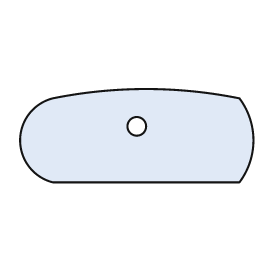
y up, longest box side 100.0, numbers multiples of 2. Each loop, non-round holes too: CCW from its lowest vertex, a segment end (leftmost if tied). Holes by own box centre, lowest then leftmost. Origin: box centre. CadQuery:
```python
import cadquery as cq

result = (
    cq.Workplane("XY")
    .moveTo(-36.0, -20.0)
    .lineTo(44.0, -20.0)
    .threePointArc((50.0, -2.0), (44.0, 16.0))
    .threePointArc((4.0, 20.0), (-36.0, 16.0))
    .threePointArc((-50.0, -2.0), (-36.0, -20.0))
    .close()
    .moveTo(0.0, 4.0)
    .circle(4.0)
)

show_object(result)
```